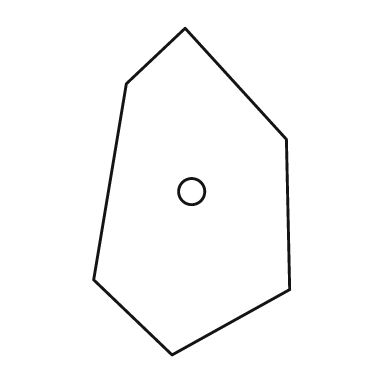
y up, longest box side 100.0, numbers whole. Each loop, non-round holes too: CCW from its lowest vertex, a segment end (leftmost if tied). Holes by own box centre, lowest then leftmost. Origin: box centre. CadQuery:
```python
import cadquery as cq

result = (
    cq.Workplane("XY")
    .moveTo(-6.0, -50.0)
    .lineTo(30.0, -30.0)
    .lineTo(29.0, 16.0)
    .lineTo(-2.0, 50.0)
    .lineTo(-20.0, 33.0)
    .lineTo(-30.0, -27.0)
    .close()
    .moveTo(0.0, 0.0)
    .circle(4.0)
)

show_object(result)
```